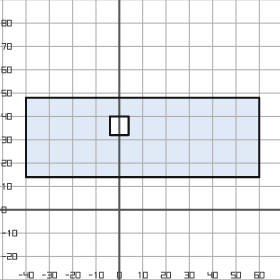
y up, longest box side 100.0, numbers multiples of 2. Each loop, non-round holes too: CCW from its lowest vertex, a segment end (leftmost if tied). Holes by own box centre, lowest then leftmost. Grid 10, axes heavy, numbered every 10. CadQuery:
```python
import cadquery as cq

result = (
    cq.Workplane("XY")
    .moveTo(-40.0, 14.0)
    .lineTo(60.0, 14.0)
    .lineTo(60.0, 48.0)
    .lineTo(-40.0, 48.0)
    .close()
    .moveTo(-4.0, 32.0)
    .lineTo(4.0, 32.0)
    .lineTo(4.0, 40.0)
    .lineTo(-4.0, 40.0)
    .close()
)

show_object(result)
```